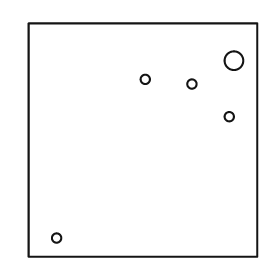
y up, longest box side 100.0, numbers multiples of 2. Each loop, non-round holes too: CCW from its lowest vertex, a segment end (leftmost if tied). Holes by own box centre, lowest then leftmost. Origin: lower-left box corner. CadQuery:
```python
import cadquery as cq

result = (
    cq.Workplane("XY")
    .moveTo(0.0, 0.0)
    .lineTo(98.0, 0.0)
    .lineTo(98.0, 100.0)
    .lineTo(0.0, 100.0)
    .close()
    .moveTo(12.0, 8.0)
    .circle(2.0)
    .moveTo(86.0, 60.0)
    .circle(2.0)
    .moveTo(70.0, 74.0)
    .circle(2.0)
    .moveTo(50.0, 76.0)
    .circle(2.0)
    .moveTo(88.0, 84.0)
    .circle(4.0)
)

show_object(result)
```